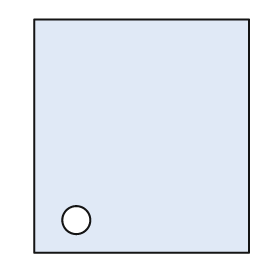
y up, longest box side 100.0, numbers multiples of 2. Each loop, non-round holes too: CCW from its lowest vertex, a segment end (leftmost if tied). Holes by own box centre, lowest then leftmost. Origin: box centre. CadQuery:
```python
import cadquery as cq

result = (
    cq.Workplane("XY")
    .moveTo(-46.0, -50.0)
    .lineTo(46.0, -50.0)
    .lineTo(46.0, 50.0)
    .lineTo(-46.0, 50.0)
    .close()
    .moveTo(-28.0, -36.0)
    .circle(6.0)
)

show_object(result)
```